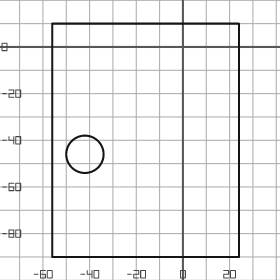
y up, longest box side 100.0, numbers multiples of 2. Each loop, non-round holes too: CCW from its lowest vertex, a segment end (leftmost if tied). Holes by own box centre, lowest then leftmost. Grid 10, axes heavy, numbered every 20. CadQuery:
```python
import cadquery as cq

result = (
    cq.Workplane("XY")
    .moveTo(-56.0, -90.0)
    .lineTo(24.0, -90.0)
    .lineTo(24.0, 10.0)
    .lineTo(-56.0, 10.0)
    .close()
    .moveTo(-42.0, -46.0)
    .circle(8.0)
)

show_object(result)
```